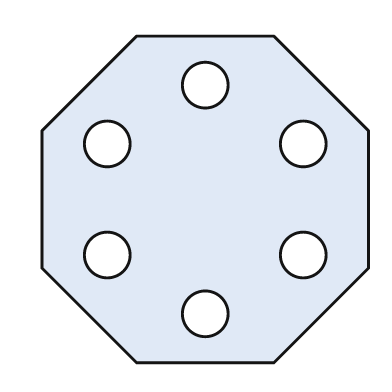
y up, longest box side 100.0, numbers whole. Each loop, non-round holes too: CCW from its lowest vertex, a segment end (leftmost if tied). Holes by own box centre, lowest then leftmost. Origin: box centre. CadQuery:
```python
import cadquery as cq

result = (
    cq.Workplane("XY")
    .moveTo(-21.0, -50.0)
    .lineTo(21.0, -50.0)
    .lineTo(50.0, -21.0)
    .lineTo(50.0, 21.0)
    .lineTo(21.0, 50.0)
    .lineTo(-21.0, 50.0)
    .lineTo(-50.0, 21.0)
    .lineTo(-50.0, -21.0)
    .close()
    .moveTo(0.0, -35.0)
    .circle(7.0)
    .moveTo(-30.0, -17.0)
    .circle(7.0)
    .moveTo(30.0, -17.0)
    .circle(7.0)
    .moveTo(-30.0, 17.0)
    .circle(7.0)
    .moveTo(30.0, 17.0)
    .circle(7.0)
    .moveTo(0.0, 35.0)
    .circle(7.0)
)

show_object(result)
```